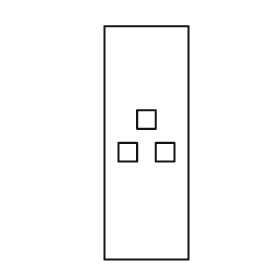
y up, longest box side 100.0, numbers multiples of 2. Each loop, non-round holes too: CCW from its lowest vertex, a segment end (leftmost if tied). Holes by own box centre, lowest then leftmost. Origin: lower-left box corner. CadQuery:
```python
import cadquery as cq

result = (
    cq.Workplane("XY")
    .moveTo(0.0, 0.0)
    .lineTo(36.0, 0.0)
    .lineTo(36.0, 100.0)
    .lineTo(0.0, 100.0)
    .close()
    .moveTo(6.0, 42.0)
    .lineTo(14.0, 42.0)
    .lineTo(14.0, 50.0)
    .lineTo(6.0, 50.0)
    .close()
    .moveTo(22.0, 42.0)
    .lineTo(30.0, 42.0)
    .lineTo(30.0, 50.0)
    .lineTo(22.0, 50.0)
    .close()
    .moveTo(14.0, 56.0)
    .lineTo(22.0, 56.0)
    .lineTo(22.0, 64.0)
    .lineTo(14.0, 64.0)
    .close()
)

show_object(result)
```